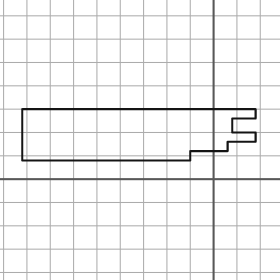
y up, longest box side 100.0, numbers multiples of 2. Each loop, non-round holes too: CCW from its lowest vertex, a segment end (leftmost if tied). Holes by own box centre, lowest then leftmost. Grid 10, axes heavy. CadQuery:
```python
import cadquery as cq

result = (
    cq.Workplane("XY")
    .moveTo(-82.0, 8.0)
    .lineTo(-10.0, 8.0)
    .lineTo(-10.0, 12.0)
    .lineTo(6.0, 12.0)
    .lineTo(6.0, 16.0)
    .lineTo(18.0, 16.0)
    .lineTo(18.0, 20.0)
    .lineTo(8.0, 20.0)
    .lineTo(8.0, 26.0)
    .lineTo(18.0, 26.0)
    .lineTo(18.0, 30.0)
    .lineTo(-82.0, 30.0)
    .close()
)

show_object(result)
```